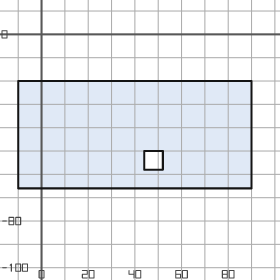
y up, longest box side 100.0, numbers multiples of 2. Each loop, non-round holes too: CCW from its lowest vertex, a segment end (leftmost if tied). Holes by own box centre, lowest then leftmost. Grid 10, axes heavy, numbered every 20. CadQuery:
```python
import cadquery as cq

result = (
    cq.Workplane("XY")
    .moveTo(-10.0, -66.0)
    .lineTo(90.0, -66.0)
    .lineTo(90.0, -20.0)
    .lineTo(-10.0, -20.0)
    .close()
    .moveTo(44.0, -58.0)
    .lineTo(52.0, -58.0)
    .lineTo(52.0, -50.0)
    .lineTo(44.0, -50.0)
    .close()
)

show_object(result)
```